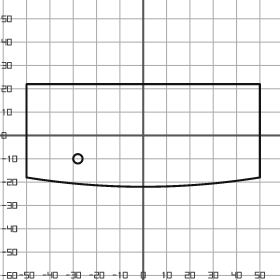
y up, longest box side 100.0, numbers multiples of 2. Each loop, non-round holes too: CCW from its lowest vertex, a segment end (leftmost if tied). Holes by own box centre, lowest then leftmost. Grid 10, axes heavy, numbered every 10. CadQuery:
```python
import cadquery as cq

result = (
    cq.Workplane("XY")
    .moveTo(-50.0, -18.0)
    .threePointArc((0.0, -22.0), (50.0, -18.0))
    .lineTo(50.0, 22.0)
    .lineTo(-50.0, 22.0)
    .close()
    .moveTo(-28.0, -10.0)
    .circle(2.0)
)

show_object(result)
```